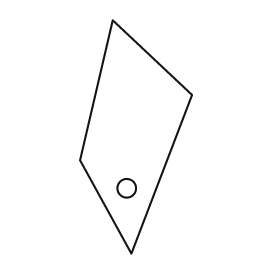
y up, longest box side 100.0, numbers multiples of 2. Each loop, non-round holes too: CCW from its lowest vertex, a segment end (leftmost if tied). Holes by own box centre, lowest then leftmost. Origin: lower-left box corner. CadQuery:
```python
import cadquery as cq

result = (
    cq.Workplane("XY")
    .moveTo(22.0, 0.0)
    .lineTo(48.0, 68.0)
    .lineTo(14.0, 100.0)
    .lineTo(0.0, 40.0)
    .close()
    .moveTo(20.0, 28.0)
    .circle(4.0)
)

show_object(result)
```